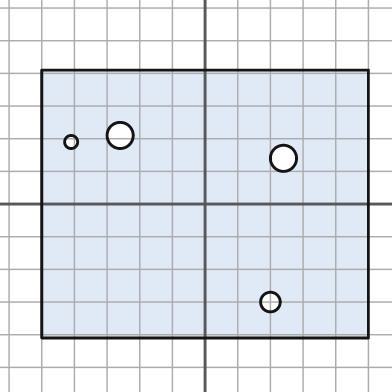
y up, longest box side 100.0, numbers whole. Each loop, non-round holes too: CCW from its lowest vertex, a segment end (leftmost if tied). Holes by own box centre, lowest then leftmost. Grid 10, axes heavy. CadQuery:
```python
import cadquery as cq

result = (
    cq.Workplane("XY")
    .moveTo(-50.0, -41.0)
    .lineTo(50.0, -41.0)
    .lineTo(50.0, 41.0)
    .lineTo(-50.0, 41.0)
    .close()
    .moveTo(20.0, -30.0)
    .circle(3.0)
    .moveTo(24.0, 14.0)
    .circle(4.0)
    .moveTo(-41.0, 19.0)
    .circle(2.0)
    .moveTo(-26.0, 21.0)
    .circle(4.0)
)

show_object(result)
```